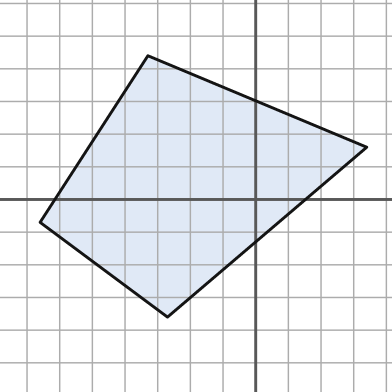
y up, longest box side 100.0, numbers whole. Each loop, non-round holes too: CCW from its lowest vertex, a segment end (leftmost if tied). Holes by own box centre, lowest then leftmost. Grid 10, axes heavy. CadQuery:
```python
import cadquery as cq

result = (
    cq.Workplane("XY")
    .moveTo(-27.0, -36.0)
    .lineTo(34.0, 16.0)
    .lineTo(-33.0, 44.0)
    .lineTo(-66.0, -7.0)
    .close()
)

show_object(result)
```